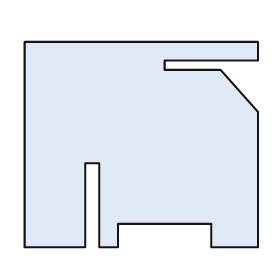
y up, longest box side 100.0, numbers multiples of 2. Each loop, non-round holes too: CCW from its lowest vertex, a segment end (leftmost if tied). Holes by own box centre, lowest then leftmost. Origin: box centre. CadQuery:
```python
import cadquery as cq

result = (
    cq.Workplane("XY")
    .moveTo(-50.0, -44.0)
    .lineTo(-24.0, -44.0)
    .lineTo(-24.0, -8.0)
    .lineTo(-18.0, -8.0)
    .lineTo(-18.0, -44.0)
    .lineTo(-10.0, -44.0)
    .lineTo(-10.0, -34.0)
    .lineTo(30.0, -34.0)
    .lineTo(30.0, -44.0)
    .lineTo(50.0, -44.0)
    .lineTo(50.0, 14.0)
    .lineTo(34.0, 32.0)
    .lineTo(10.0, 32.0)
    .lineTo(10.0, 36.0)
    .lineTo(50.0, 36.0)
    .lineTo(50.0, 44.0)
    .lineTo(-50.0, 44.0)
    .close()
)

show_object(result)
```